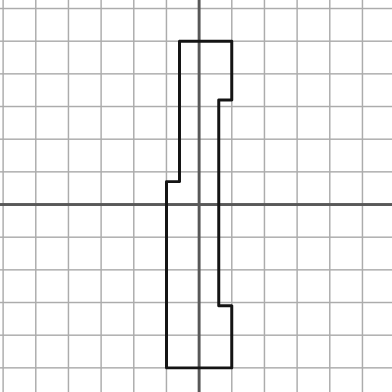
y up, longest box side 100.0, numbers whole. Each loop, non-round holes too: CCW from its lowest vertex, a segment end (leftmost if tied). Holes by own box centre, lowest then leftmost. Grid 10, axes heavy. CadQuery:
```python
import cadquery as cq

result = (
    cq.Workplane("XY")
    .moveTo(-10.0, -50.0)
    .lineTo(10.0, -50.0)
    .lineTo(10.0, -31.0)
    .lineTo(6.0, -31.0)
    .lineTo(6.0, 32.0)
    .lineTo(10.0, 32.0)
    .lineTo(10.0, 50.0)
    .lineTo(-6.0, 50.0)
    .lineTo(-6.0, 7.0)
    .lineTo(-10.0, 7.0)
    .close()
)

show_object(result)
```